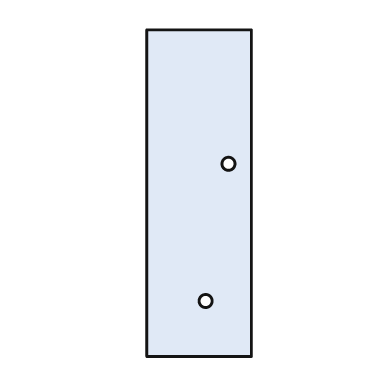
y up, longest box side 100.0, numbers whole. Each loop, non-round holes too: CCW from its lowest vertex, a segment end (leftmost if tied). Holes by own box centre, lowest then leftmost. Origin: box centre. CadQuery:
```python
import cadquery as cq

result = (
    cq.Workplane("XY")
    .moveTo(-16.0, -50.0)
    .lineTo(16.0, -50.0)
    .lineTo(16.0, 50.0)
    .lineTo(-16.0, 50.0)
    .close()
    .moveTo(2.0, -33.0)
    .circle(2.0)
    .moveTo(9.0, 9.0)
    .circle(2.0)
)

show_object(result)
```